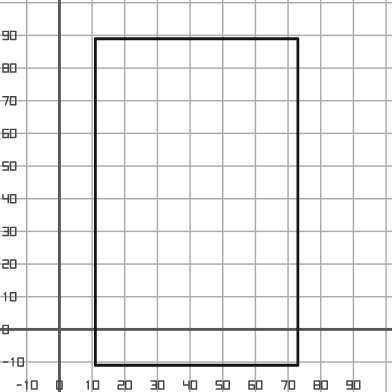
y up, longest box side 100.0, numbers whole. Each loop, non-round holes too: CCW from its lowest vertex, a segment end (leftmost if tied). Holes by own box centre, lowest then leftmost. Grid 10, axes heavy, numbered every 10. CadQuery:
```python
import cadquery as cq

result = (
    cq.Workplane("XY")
    .moveTo(11.0, -11.0)
    .lineTo(73.0, -11.0)
    .lineTo(73.0, 89.0)
    .lineTo(11.0, 89.0)
    .close()
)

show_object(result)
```